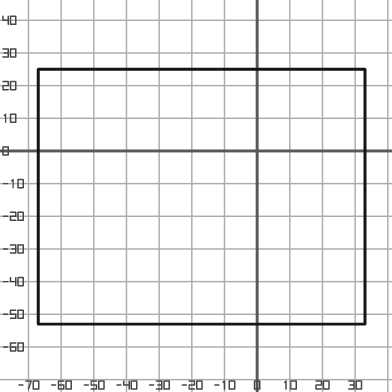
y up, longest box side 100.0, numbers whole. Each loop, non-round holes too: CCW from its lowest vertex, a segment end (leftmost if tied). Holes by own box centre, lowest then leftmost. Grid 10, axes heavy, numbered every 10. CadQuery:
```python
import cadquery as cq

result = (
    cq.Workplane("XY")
    .moveTo(-67.0, -53.0)
    .lineTo(33.0, -53.0)
    .lineTo(33.0, 25.0)
    .lineTo(-67.0, 25.0)
    .close()
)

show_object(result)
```